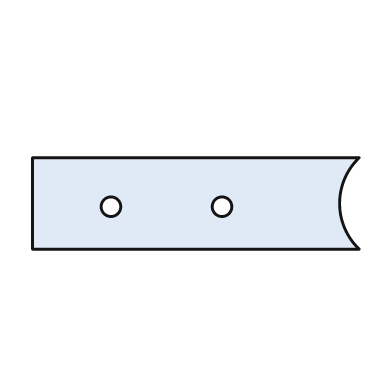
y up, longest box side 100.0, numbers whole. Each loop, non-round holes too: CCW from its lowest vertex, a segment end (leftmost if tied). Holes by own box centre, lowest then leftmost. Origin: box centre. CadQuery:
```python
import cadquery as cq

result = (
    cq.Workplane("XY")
    .moveTo(-50.0, -14.0)
    .lineTo(50.0, -14.0)
    .threePointArc((44.0, 0.0), (50.0, 14.0))
    .lineTo(-50.0, 14.0)
    .close()
    .moveTo(-26.0, -1.0)
    .circle(3.0)
    .moveTo(8.0, -1.0)
    .circle(3.0)
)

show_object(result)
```